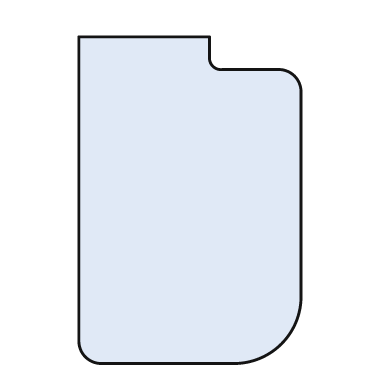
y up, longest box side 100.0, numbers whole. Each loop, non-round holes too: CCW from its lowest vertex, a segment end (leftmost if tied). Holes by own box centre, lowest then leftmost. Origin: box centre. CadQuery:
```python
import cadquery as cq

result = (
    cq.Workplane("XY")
    .moveTo(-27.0, -50.0)
    .lineTo(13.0, -50.0)
    .threePointArc((28.0, -44.0), (34.0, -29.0))
    .lineTo(34.0, 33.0)
    .threePointArc((32.0, 38.0), (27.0, 40.0))
    .lineTo(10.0, 40.0)
    .threePointArc((7.0, 41.0), (6.0, 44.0))
    .lineTo(6.0, 50.0)
    .lineTo(-34.0, 50.0)
    .lineTo(-34.0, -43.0)
    .threePointArc((-32.0, -48.0), (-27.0, -50.0))
    .close()
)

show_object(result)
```